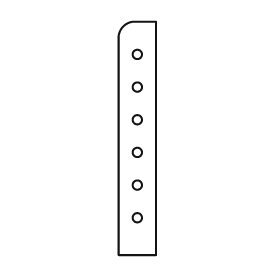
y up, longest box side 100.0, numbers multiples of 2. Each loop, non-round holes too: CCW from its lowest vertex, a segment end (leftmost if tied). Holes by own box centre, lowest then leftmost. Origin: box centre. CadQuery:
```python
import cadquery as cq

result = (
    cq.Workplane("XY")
    .moveTo(-8.0, -50.0)
    .lineTo(8.0, -50.0)
    .lineTo(8.0, 50.0)
    .lineTo(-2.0, 50.0)
    .threePointArc((-6.0, 48.0), (-8.0, 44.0))
    .close()
    .moveTo(0.0, -34.0)
    .circle(2.0)
    .moveTo(0.0, -20.0)
    .circle(2.0)
    .moveTo(0.0, -6.0)
    .circle(2.0)
    .moveTo(0.0, 8.0)
    .circle(2.0)
    .moveTo(0.0, 22.0)
    .circle(2.0)
    .moveTo(0.0, 36.0)
    .circle(2.0)
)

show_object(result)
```